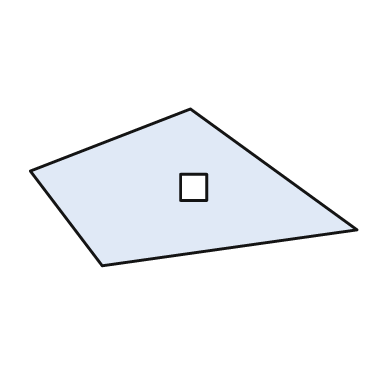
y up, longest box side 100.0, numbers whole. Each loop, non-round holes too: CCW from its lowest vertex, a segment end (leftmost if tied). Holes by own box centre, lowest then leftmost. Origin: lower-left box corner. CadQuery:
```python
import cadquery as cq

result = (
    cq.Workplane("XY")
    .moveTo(22.0, 0.0)
    .lineTo(100.0, 11.0)
    .lineTo(49.0, 48.0)
    .lineTo(0.0, 29.0)
    .close()
    .moveTo(46.0, 20.0)
    .lineTo(54.0, 20.0)
    .lineTo(54.0, 28.0)
    .lineTo(46.0, 28.0)
    .close()
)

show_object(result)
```